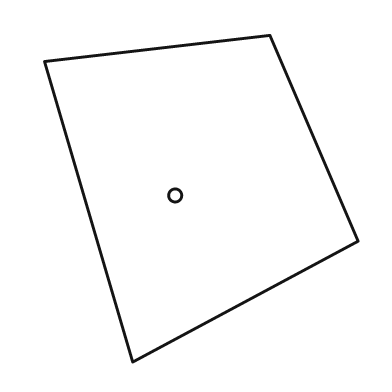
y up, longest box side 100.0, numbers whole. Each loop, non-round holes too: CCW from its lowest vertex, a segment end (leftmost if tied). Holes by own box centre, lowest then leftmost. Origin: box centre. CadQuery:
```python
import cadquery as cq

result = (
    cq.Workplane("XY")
    .moveTo(-21.0, -50.0)
    .lineTo(48.0, -13.0)
    .lineTo(21.0, 50.0)
    .lineTo(-48.0, 42.0)
    .close()
    .moveTo(-8.0, 1.0)
    .circle(2.0)
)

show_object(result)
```